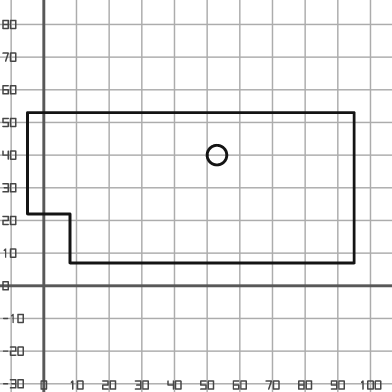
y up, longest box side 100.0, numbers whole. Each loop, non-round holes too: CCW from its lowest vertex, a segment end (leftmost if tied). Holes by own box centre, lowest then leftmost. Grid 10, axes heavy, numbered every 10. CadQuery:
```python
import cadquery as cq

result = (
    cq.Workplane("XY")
    .moveTo(8.0, 7.0)
    .lineTo(95.0, 7.0)
    .lineTo(95.0, 53.0)
    .lineTo(-5.0, 53.0)
    .lineTo(-5.0, 22.0)
    .lineTo(8.0, 22.0)
    .close()
    .moveTo(53.0, 40.0)
    .circle(3.0)
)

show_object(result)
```